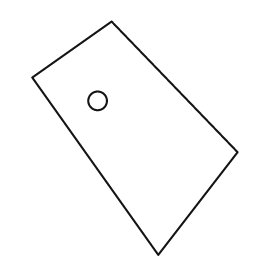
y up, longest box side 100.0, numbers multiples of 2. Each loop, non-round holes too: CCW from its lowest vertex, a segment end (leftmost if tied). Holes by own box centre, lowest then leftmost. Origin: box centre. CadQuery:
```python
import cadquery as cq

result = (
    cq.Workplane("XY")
    .moveTo(10.0, -50.0)
    .lineTo(44.0, -6.0)
    .lineTo(-10.0, 50.0)
    .lineTo(-44.0, 26.0)
    .close()
    .moveTo(-16.0, 16.0)
    .circle(4.0)
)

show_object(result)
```